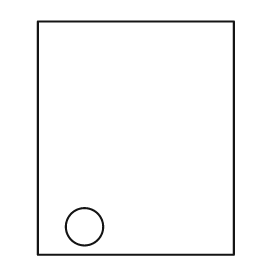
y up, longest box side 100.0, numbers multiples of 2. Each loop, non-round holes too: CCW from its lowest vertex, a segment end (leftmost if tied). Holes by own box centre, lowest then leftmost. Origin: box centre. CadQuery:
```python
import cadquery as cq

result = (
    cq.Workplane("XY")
    .moveTo(-42.0, -50.0)
    .lineTo(42.0, -50.0)
    .lineTo(42.0, 50.0)
    .lineTo(-42.0, 50.0)
    .close()
    .moveTo(-22.0, -38.0)
    .circle(8.0)
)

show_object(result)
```